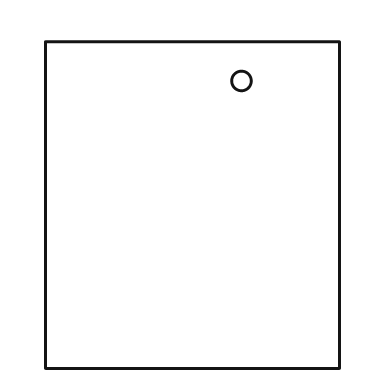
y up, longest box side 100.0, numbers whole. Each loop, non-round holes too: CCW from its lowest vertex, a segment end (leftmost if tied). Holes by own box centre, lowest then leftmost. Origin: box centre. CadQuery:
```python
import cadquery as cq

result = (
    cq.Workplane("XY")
    .moveTo(-45.0, -50.0)
    .lineTo(45.0, -50.0)
    .lineTo(45.0, 50.0)
    .lineTo(-45.0, 50.0)
    .close()
    .moveTo(15.0, 38.0)
    .circle(3.0)
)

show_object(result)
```